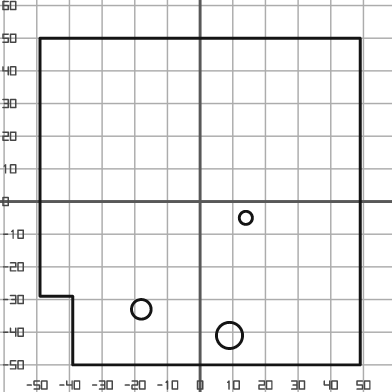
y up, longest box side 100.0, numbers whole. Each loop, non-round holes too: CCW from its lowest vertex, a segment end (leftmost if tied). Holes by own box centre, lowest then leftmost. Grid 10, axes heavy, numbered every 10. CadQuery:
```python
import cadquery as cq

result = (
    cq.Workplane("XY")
    .moveTo(-39.0, -50.0)
    .lineTo(49.0, -50.0)
    .lineTo(49.0, 50.0)
    .lineTo(-49.0, 50.0)
    .lineTo(-49.0, -29.0)
    .lineTo(-39.0, -29.0)
    .close()
    .moveTo(9.0, -41.0)
    .circle(4.0)
    .moveTo(-18.0, -33.0)
    .circle(3.0)
    .moveTo(14.0, -5.0)
    .circle(2.0)
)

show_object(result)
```